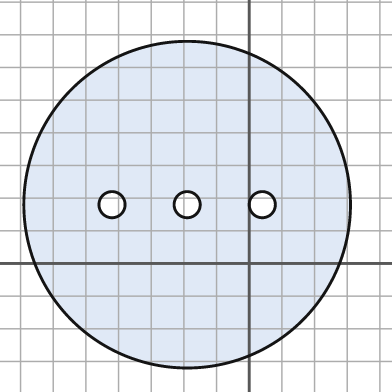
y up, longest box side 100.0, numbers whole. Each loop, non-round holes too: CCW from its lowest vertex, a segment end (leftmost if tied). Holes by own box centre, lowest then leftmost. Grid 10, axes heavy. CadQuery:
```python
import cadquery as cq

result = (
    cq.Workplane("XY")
    .moveTo(-19.0, 18.0)
    .circle(50.0)
    .moveTo(-42.0, 18.0)
    .circle(4.0)
    .moveTo(-19.0, 18.0)
    .circle(4.0)
    .moveTo(4.0, 18.0)
    .circle(4.0)
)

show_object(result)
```